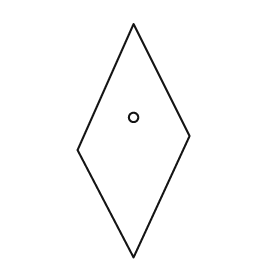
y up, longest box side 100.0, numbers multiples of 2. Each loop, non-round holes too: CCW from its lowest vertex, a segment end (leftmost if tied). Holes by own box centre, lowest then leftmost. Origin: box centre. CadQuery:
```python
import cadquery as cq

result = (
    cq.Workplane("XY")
    .moveTo(0.0, -50.0)
    .lineTo(24.0, 2.0)
    .lineTo(0.0, 50.0)
    .lineTo(-24.0, -4.0)
    .close()
    .moveTo(0.0, 10.0)
    .circle(2.0)
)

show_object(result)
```